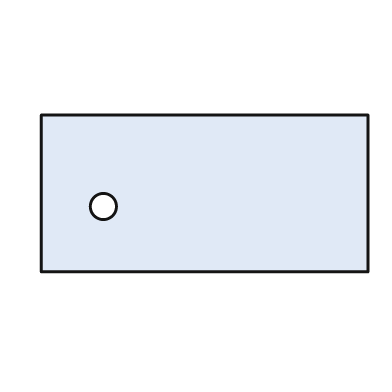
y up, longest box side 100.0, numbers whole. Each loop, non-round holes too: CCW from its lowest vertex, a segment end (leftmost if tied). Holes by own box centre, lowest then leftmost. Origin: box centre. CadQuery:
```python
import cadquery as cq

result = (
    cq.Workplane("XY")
    .moveTo(-50.0, -24.0)
    .lineTo(50.0, -24.0)
    .lineTo(50.0, 24.0)
    .lineTo(-50.0, 24.0)
    .close()
    .moveTo(-31.0, -4.0)
    .circle(4.0)
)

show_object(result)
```